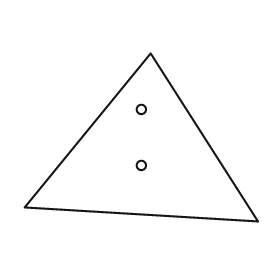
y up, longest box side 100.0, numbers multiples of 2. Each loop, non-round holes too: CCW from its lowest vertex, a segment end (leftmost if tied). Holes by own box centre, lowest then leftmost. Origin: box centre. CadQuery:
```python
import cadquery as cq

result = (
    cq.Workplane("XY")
    .moveTo(50.0, -36.0)
    .lineTo(4.0, 36.0)
    .lineTo(-50.0, -30.0)
    .close()
    .moveTo(0.0, -12.0)
    .circle(2.0)
    .moveTo(0.0, 12.0)
    .circle(2.0)
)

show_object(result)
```